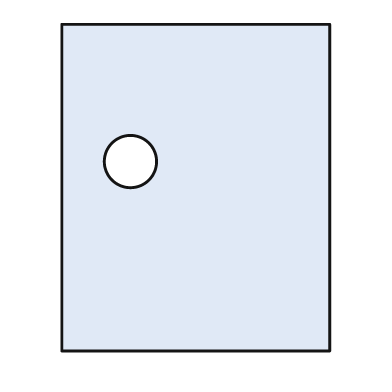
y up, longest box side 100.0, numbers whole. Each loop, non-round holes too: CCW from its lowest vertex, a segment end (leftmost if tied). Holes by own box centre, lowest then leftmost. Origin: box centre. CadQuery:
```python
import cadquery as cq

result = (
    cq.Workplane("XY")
    .moveTo(-41.0, -50.0)
    .lineTo(41.0, -50.0)
    .lineTo(41.0, 50.0)
    .lineTo(-41.0, 50.0)
    .close()
    .moveTo(-20.0, 8.0)
    .circle(8.0)
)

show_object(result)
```